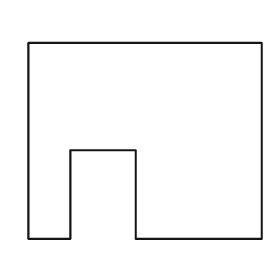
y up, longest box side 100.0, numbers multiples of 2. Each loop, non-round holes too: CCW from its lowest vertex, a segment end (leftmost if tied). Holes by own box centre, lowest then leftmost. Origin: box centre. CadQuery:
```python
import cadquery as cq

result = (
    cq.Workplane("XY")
    .moveTo(-50.0, -42.0)
    .lineTo(-32.0, -42.0)
    .lineTo(-32.0, -4.0)
    .lineTo(-4.0, -4.0)
    .lineTo(-4.0, -42.0)
    .lineTo(50.0, -42.0)
    .lineTo(50.0, 42.0)
    .lineTo(-50.0, 42.0)
    .close()
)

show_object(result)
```